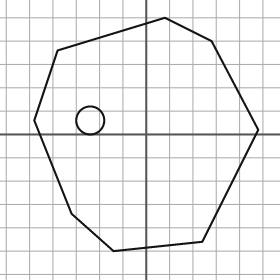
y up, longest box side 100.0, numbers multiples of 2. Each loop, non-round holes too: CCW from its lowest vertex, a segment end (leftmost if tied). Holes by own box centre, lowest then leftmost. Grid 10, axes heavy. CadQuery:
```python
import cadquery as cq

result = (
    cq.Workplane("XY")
    .moveTo(-14.0, -50.0)
    .lineTo(24.0, -46.0)
    .lineTo(48.0, 2.0)
    .lineTo(28.0, 40.0)
    .lineTo(8.0, 50.0)
    .lineTo(-38.0, 36.0)
    .lineTo(-48.0, 6.0)
    .lineTo(-32.0, -34.0)
    .close()
    .moveTo(-24.0, 6.0)
    .circle(6.0)
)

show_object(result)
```